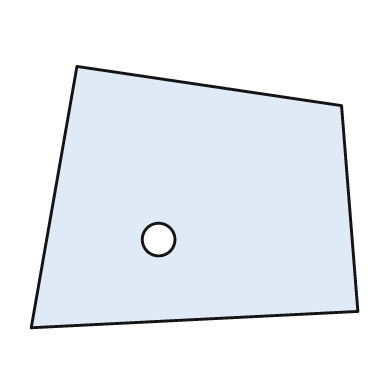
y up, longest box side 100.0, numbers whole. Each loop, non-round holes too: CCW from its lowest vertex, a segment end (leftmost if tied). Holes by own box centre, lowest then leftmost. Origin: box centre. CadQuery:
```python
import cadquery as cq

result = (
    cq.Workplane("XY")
    .moveTo(-50.0, -40.0)
    .lineTo(50.0, -35.0)
    .lineTo(45.0, 28.0)
    .lineTo(-36.0, 40.0)
    .close()
    .moveTo(-11.0, -13.0)
    .circle(5.0)
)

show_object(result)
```